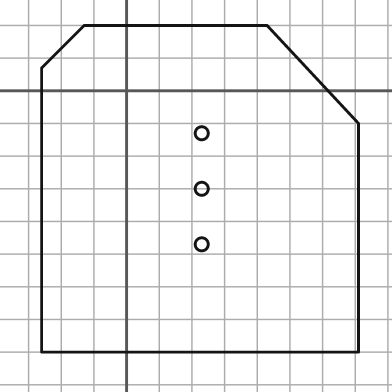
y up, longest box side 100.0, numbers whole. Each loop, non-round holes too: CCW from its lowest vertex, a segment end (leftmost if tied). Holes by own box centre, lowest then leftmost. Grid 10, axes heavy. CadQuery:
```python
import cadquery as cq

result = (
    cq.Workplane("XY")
    .moveTo(-26.0, -80.0)
    .lineTo(71.0, -80.0)
    .lineTo(71.0, -10.0)
    .lineTo(43.0, 20.0)
    .lineTo(-13.0, 20.0)
    .lineTo(-26.0, 7.0)
    .close()
    .moveTo(23.0, -47.0)
    .circle(2.0)
    .moveTo(23.0, -30.0)
    .circle(2.0)
    .moveTo(23.0, -13.0)
    .circle(2.0)
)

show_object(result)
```